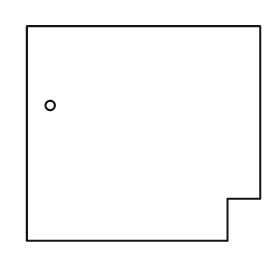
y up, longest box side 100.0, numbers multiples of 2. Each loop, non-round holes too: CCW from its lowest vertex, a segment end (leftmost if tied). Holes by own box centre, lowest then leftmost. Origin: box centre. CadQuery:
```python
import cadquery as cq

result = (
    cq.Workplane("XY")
    .moveTo(-50.0, -46.0)
    .lineTo(36.0, -46.0)
    .lineTo(36.0, -28.0)
    .lineTo(50.0, -28.0)
    .lineTo(50.0, 46.0)
    .lineTo(-50.0, 46.0)
    .close()
    .moveTo(-40.0, 12.0)
    .circle(2.0)
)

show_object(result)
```